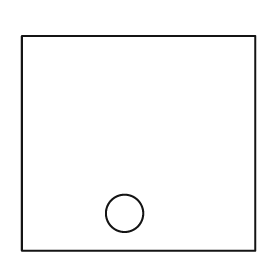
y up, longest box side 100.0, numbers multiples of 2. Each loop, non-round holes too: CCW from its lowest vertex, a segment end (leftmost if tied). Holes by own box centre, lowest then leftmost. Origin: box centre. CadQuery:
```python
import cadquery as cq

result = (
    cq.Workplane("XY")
    .moveTo(-50.0, -46.0)
    .lineTo(50.0, -46.0)
    .lineTo(50.0, 46.0)
    .lineTo(-50.0, 46.0)
    .close()
    .moveTo(-6.0, -30.0)
    .circle(8.0)
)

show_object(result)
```